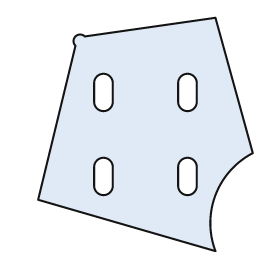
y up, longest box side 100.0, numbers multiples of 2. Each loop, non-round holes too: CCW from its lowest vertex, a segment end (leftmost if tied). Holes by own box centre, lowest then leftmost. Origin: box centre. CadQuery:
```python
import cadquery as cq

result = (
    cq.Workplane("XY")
    .moveTo(30.0, -50.0)
    .threePointArc((30.0, -26.0), (46.0, -8.0))
    .lineTo(30.0, 50.0)
    .lineTo(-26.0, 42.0)
    .threePointArc((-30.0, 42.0), (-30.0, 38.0))
    .lineTo(-46.0, -28.0)
    .close()
    .moveTo(-22.0, -22.0)
    .threePointArc((-18.0, -26.0), (-14.0, -22.0))
    .lineTo(-14.0, -14.0)
    .threePointArc((-18.0, -10.0), (-22.0, -14.0))
    .close()
    .moveTo(14.0, -22.0)
    .threePointArc((18.0, -26.0), (22.0, -22.0))
    .lineTo(22.0, -14.0)
    .threePointArc((18.0, -10.0), (14.0, -14.0))
    .close()
    .moveTo(-22.0, 14.0)
    .threePointArc((-18.0, 10.0), (-14.0, 14.0))
    .lineTo(-14.0, 22.0)
    .threePointArc((-18.0, 26.0), (-22.0, 22.0))
    .close()
    .moveTo(14.0, 14.0)
    .threePointArc((18.0, 10.0), (22.0, 14.0))
    .lineTo(22.0, 22.0)
    .threePointArc((18.0, 26.0), (14.0, 22.0))
    .close()
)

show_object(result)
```